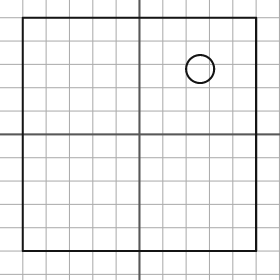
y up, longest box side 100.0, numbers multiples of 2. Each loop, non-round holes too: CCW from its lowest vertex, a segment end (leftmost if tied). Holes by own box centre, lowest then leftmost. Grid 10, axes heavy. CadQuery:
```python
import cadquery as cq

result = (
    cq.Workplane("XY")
    .moveTo(-50.0, -50.0)
    .lineTo(50.0, -50.0)
    .lineTo(50.0, 50.0)
    .lineTo(-50.0, 50.0)
    .close()
    .moveTo(26.0, 28.0)
    .circle(6.0)
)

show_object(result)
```